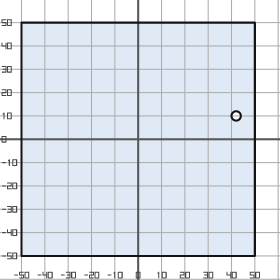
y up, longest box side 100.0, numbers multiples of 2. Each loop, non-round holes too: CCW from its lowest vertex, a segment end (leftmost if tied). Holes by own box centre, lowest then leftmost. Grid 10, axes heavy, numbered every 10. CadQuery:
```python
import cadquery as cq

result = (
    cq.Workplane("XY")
    .moveTo(-50.0, -50.0)
    .lineTo(50.0, -50.0)
    .lineTo(50.0, 50.0)
    .lineTo(-50.0, 50.0)
    .close()
    .moveTo(42.0, 10.0)
    .circle(2.0)
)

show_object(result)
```